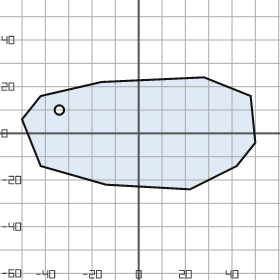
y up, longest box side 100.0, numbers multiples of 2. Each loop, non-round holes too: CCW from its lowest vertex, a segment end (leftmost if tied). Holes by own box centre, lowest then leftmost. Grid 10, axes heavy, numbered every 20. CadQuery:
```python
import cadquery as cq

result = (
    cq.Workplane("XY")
    .moveTo(22.0, -24.0)
    .lineTo(42.0, -14.0)
    .lineTo(50.0, -4.0)
    .lineTo(48.0, 16.0)
    .lineTo(28.0, 24.0)
    .lineTo(-16.0, 22.0)
    .lineTo(-42.0, 16.0)
    .lineTo(-50.0, 6.0)
    .lineTo(-42.0, -14.0)
    .lineTo(-14.0, -22.0)
    .close()
    .moveTo(-34.0, 10.0)
    .circle(2.0)
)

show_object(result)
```